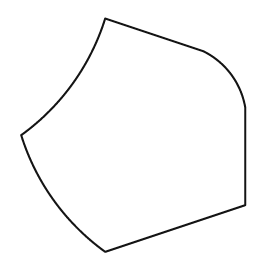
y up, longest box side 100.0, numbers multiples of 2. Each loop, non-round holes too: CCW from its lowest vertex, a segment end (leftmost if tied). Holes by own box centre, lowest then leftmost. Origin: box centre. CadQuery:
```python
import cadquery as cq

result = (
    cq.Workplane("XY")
    .moveTo(-12.0, -50.0)
    .lineTo(48.0, -30.0)
    .lineTo(48.0, 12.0)
    .threePointArc((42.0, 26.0), (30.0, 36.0))
    .lineTo(-12.0, 50.0)
    .threePointArc((-26.0, 22.0), (-48.0, 0.0))
    .threePointArc((-34.0, -28.0), (-12.0, -50.0))
    .close()
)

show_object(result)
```